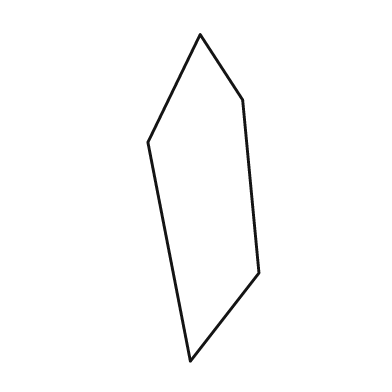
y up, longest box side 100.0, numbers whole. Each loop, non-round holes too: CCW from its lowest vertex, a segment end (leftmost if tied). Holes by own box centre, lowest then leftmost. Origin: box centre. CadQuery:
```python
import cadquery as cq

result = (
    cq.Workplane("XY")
    .moveTo(-4.0, -50.0)
    .lineTo(17.0, -23.0)
    .lineTo(12.0, 30.0)
    .lineTo(-1.0, 50.0)
    .lineTo(-17.0, 17.0)
    .close()
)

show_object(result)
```